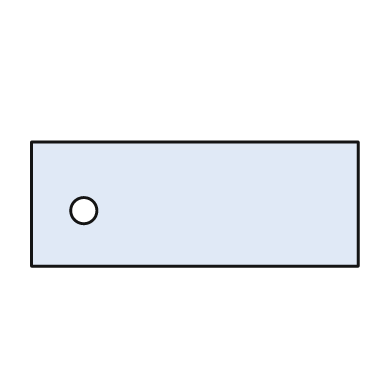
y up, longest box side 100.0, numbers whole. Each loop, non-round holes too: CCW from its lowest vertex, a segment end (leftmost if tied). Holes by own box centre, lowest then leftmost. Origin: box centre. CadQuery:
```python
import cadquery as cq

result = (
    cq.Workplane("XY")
    .moveTo(-50.0, -19.0)
    .lineTo(50.0, -19.0)
    .lineTo(50.0, 19.0)
    .lineTo(-50.0, 19.0)
    .close()
    .moveTo(-34.0, -2.0)
    .circle(4.0)
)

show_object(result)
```